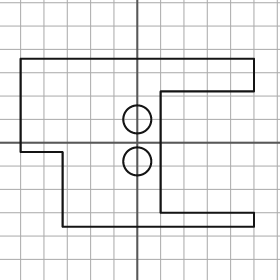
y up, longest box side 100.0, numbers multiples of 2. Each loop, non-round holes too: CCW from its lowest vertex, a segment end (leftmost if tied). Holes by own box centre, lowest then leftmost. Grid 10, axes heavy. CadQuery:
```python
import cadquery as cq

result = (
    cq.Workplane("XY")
    .moveTo(-32.0, -36.0)
    .lineTo(50.0, -36.0)
    .lineTo(50.0, -30.0)
    .lineTo(10.0, -30.0)
    .lineTo(10.0, 22.0)
    .lineTo(50.0, 22.0)
    .lineTo(50.0, 36.0)
    .lineTo(-50.0, 36.0)
    .lineTo(-50.0, -4.0)
    .lineTo(-32.0, -4.0)
    .close()
    .moveTo(0.0, -8.0)
    .circle(6.0)
    .moveTo(0.0, 10.0)
    .circle(6.0)
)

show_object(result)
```